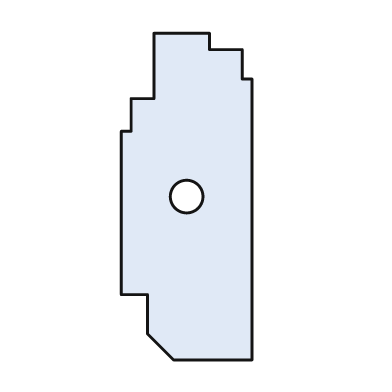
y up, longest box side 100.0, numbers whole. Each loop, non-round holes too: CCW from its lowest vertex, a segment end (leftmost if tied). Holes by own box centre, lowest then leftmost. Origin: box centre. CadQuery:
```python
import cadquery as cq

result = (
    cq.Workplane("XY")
    .moveTo(-4.0, -50.0)
    .lineTo(20.0, -50.0)
    .lineTo(20.0, 36.0)
    .lineTo(17.0, 36.0)
    .lineTo(17.0, 45.0)
    .lineTo(7.0, 45.0)
    .lineTo(7.0, 50.0)
    .lineTo(-10.0, 50.0)
    .lineTo(-10.0, 30.0)
    .lineTo(-17.0, 30.0)
    .lineTo(-17.0, 20.0)
    .lineTo(-20.0, 20.0)
    .lineTo(-20.0, -30.0)
    .lineTo(-12.0, -30.0)
    .lineTo(-12.0, -42.0)
    .close()
    .moveTo(0.0, 0.0)
    .circle(5.0)
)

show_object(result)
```